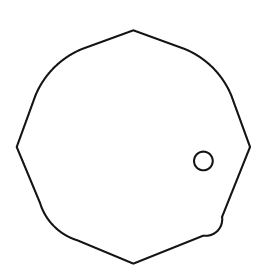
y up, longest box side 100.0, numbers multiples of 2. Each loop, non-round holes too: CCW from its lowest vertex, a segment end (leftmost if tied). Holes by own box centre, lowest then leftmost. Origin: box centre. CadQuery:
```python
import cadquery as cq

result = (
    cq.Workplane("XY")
    .moveTo(0.0, -50.0)
    .lineTo(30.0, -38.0)
    .threePointArc((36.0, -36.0), (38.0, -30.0))
    .lineTo(50.0, 0.0)
    .lineTo(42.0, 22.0)
    .threePointArc((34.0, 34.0), (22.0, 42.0))
    .lineTo(0.0, 50.0)
    .lineTo(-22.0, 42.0)
    .threePointArc((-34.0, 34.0), (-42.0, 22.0))
    .lineTo(-50.0, 0.0)
    .lineTo(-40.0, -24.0)
    .threePointArc((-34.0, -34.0), (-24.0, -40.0))
    .close()
    .moveTo(30.0, -6.0)
    .circle(4.0)
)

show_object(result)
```